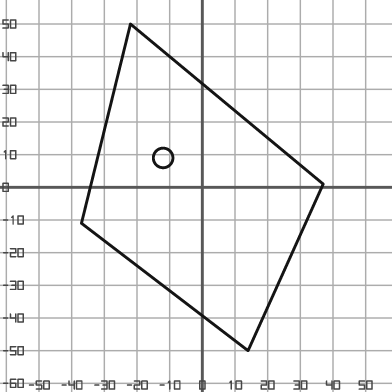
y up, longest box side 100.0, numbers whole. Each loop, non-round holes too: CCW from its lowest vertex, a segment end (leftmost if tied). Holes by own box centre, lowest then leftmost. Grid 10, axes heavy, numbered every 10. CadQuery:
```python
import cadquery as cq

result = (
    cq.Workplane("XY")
    .moveTo(14.0, -50.0)
    .lineTo(37.0, 1.0)
    .lineTo(-22.0, 50.0)
    .lineTo(-37.0, -11.0)
    .close()
    .moveTo(-12.0, 9.0)
    .circle(3.0)
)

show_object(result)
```